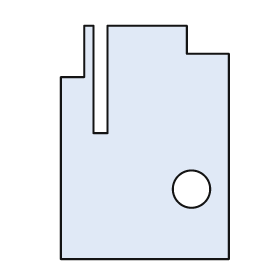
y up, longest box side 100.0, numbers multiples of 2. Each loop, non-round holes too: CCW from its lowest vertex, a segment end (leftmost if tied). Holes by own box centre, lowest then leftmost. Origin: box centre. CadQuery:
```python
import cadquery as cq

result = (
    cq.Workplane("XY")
    .moveTo(-36.0, -50.0)
    .lineTo(36.0, -50.0)
    .lineTo(36.0, 38.0)
    .lineTo(18.0, 38.0)
    .lineTo(18.0, 50.0)
    .lineTo(-16.0, 50.0)
    .lineTo(-16.0, 4.0)
    .lineTo(-22.0, 4.0)
    .lineTo(-22.0, 50.0)
    .lineTo(-26.0, 50.0)
    .lineTo(-26.0, 28.0)
    .lineTo(-36.0, 28.0)
    .close()
    .moveTo(20.0, -20.0)
    .circle(8.0)
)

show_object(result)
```